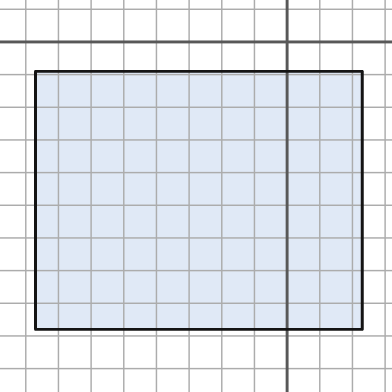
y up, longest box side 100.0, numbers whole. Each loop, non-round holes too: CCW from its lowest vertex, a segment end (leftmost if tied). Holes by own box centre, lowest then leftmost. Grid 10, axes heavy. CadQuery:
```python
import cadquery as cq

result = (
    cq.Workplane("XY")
    .moveTo(-77.0, -88.0)
    .lineTo(23.0, -88.0)
    .lineTo(23.0, -9.0)
    .lineTo(-77.0, -9.0)
    .close()
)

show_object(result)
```